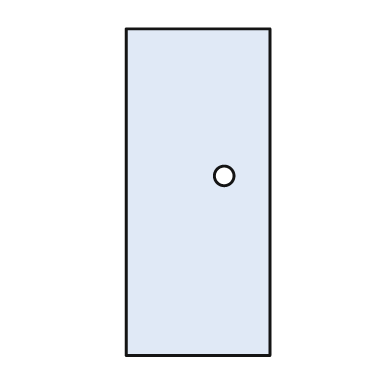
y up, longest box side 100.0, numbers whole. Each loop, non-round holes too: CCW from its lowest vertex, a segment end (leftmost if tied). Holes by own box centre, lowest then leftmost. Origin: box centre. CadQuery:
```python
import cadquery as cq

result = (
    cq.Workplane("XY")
    .moveTo(-22.0, -50.0)
    .lineTo(22.0, -50.0)
    .lineTo(22.0, 50.0)
    .lineTo(-22.0, 50.0)
    .close()
    .moveTo(8.0, 5.0)
    .circle(3.0)
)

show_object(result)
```